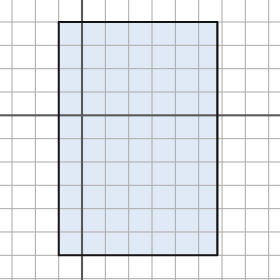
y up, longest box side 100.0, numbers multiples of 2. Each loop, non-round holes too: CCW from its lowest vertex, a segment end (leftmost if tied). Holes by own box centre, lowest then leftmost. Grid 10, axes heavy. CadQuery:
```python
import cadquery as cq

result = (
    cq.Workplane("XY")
    .moveTo(-10.0, -60.0)
    .lineTo(58.0, -60.0)
    .lineTo(58.0, 40.0)
    .lineTo(-10.0, 40.0)
    .close()
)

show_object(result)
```